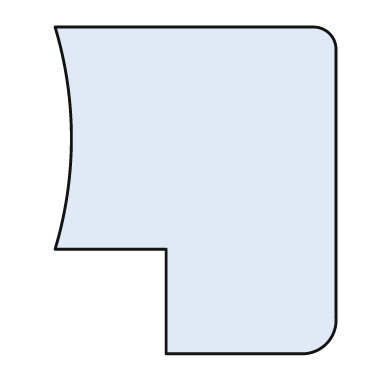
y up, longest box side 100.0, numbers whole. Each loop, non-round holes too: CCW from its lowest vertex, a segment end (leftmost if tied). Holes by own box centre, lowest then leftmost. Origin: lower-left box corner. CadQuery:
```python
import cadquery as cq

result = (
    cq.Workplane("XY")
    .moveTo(34.0, 0.0)
    .lineTo(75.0, 0.0)
    .threePointArc((83.0, 3.0), (86.0, 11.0))
    .lineTo(86.0, 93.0)
    .threePointArc((84.0, 98.0), (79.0, 100.0))
    .lineTo(0.0, 100.0)
    .threePointArc((5.0, 66.0), (0.0, 32.0))
    .lineTo(34.0, 32.0)
    .close()
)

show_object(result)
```